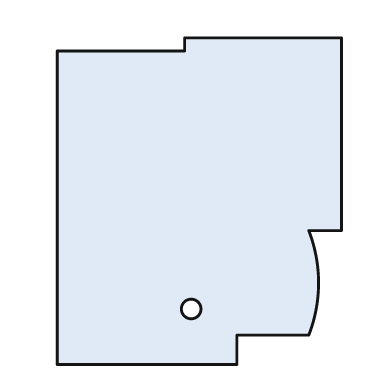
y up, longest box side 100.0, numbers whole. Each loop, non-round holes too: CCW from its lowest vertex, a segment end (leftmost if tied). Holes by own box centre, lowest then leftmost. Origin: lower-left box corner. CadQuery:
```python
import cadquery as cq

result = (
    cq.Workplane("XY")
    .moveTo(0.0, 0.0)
    .lineTo(55.0, 0.0)
    .lineTo(55.0, 9.0)
    .lineTo(77.0, 9.0)
    .threePointArc((80.0, 25.0), (77.0, 41.0))
    .lineTo(87.0, 41.0)
    .lineTo(87.0, 100.0)
    .lineTo(39.0, 100.0)
    .lineTo(39.0, 96.0)
    .lineTo(0.0, 96.0)
    .close()
    .moveTo(41.0, 17.0)
    .circle(3.0)
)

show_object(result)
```